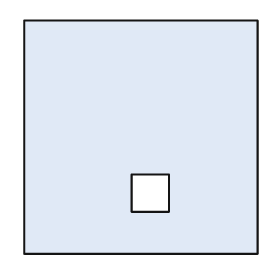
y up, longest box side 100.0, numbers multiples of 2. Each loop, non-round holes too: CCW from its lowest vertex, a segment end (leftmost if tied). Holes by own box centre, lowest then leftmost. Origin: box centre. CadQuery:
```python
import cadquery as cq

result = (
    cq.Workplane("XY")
    .moveTo(-50.0, -50.0)
    .lineTo(50.0, -50.0)
    .lineTo(50.0, 50.0)
    .lineTo(-50.0, 50.0)
    .close()
    .moveTo(-4.0, -32.0)
    .lineTo(12.0, -32.0)
    .lineTo(12.0, -16.0)
    .lineTo(-4.0, -16.0)
    .close()
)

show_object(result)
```